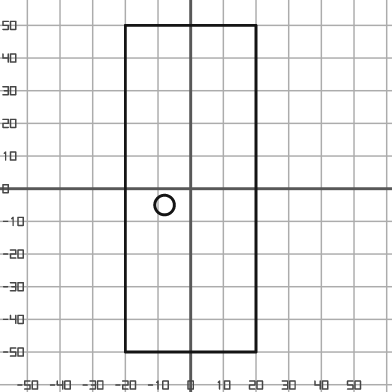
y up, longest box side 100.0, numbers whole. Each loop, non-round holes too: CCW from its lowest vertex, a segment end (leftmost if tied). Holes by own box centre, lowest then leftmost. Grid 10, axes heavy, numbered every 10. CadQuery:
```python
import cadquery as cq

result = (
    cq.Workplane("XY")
    .moveTo(-20.0, -50.0)
    .lineTo(20.0, -50.0)
    .lineTo(20.0, 50.0)
    .lineTo(-20.0, 50.0)
    .close()
    .moveTo(-8.0, -5.0)
    .circle(3.0)
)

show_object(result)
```